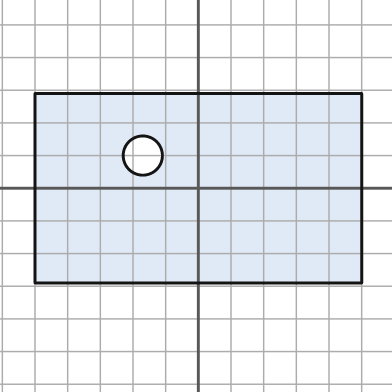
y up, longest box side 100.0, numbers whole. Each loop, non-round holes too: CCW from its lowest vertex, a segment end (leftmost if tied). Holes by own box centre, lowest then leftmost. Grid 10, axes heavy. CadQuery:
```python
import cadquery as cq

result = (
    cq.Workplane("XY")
    .moveTo(-50.0, -29.0)
    .lineTo(50.0, -29.0)
    .lineTo(50.0, 29.0)
    .lineTo(-50.0, 29.0)
    .close()
    .moveTo(-17.0, 10.0)
    .circle(6.0)
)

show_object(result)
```